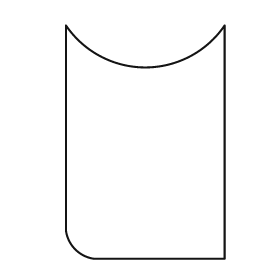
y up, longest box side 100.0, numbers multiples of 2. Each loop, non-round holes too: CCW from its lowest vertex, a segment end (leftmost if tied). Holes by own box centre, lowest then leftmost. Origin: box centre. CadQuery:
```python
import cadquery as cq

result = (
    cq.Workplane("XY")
    .moveTo(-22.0, -50.0)
    .lineTo(34.0, -50.0)
    .lineTo(34.0, 50.0)
    .threePointArc((0.0, 32.0), (-34.0, 50.0))
    .lineTo(-34.0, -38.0)
    .threePointArc((-30.0, -46.0), (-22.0, -50.0))
    .close()
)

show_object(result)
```